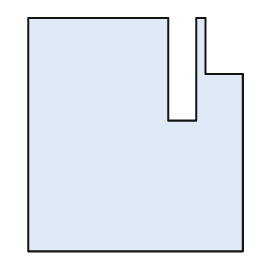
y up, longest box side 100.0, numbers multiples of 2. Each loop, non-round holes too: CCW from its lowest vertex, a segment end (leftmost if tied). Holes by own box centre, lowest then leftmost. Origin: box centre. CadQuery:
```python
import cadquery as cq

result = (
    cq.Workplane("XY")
    .moveTo(-46.0, -50.0)
    .lineTo(46.0, -50.0)
    .lineTo(46.0, 26.0)
    .lineTo(30.0, 26.0)
    .lineTo(30.0, 50.0)
    .lineTo(26.0, 50.0)
    .lineTo(26.0, 6.0)
    .lineTo(14.0, 6.0)
    .lineTo(14.0, 50.0)
    .lineTo(-46.0, 50.0)
    .close()
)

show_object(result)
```